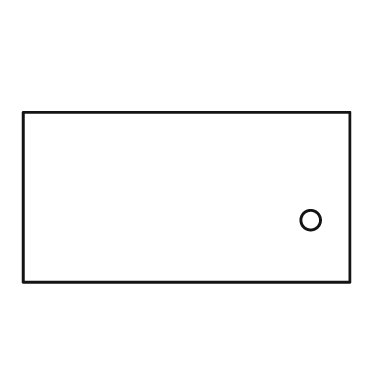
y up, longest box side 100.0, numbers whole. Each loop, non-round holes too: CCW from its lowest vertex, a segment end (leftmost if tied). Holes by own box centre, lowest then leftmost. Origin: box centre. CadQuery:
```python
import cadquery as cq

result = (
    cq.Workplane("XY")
    .moveTo(-50.0, -26.0)
    .lineTo(50.0, -26.0)
    .lineTo(50.0, 26.0)
    .lineTo(-50.0, 26.0)
    .close()
    .moveTo(38.0, -7.0)
    .circle(3.0)
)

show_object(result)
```